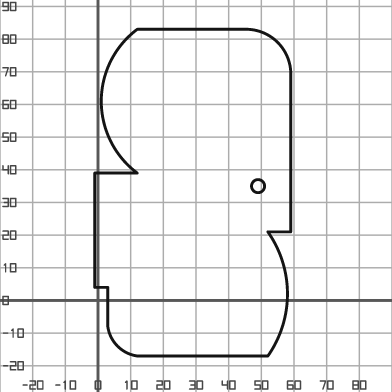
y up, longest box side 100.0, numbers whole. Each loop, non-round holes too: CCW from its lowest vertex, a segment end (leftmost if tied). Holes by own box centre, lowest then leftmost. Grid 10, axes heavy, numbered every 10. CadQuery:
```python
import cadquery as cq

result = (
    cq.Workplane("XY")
    .moveTo(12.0, -17.0)
    .lineTo(52.0, -17.0)
    .threePointArc((58.0, 2.0), (52.0, 21.0))
    .lineTo(59.0, 21.0)
    .lineTo(59.0, 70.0)
    .threePointArc((55.0, 79.0), (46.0, 83.0))
    .lineTo(12.0, 83.0)
    .threePointArc((1.0, 61.0), (12.0, 39.0))
    .lineTo(-1.0, 39.0)
    .lineTo(-1.0, 4.0)
    .lineTo(3.0, 4.0)
    .lineTo(3.0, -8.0)
    .threePointArc((6.0, -14.0), (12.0, -17.0))
    .close()
    .moveTo(49.0, 35.0)
    .circle(2.0)
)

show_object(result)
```